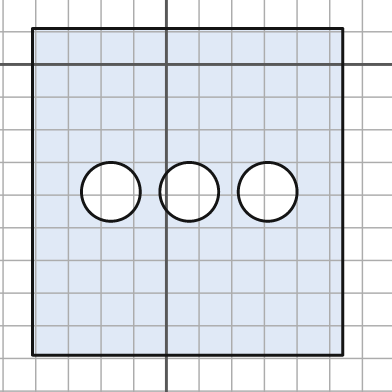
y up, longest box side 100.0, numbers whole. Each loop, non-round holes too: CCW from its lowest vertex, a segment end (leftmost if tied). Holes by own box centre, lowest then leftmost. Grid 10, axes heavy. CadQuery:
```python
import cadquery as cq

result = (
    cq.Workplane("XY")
    .moveTo(-41.0, -89.0)
    .lineTo(54.0, -89.0)
    .lineTo(54.0, 11.0)
    .lineTo(-41.0, 11.0)
    .close()
    .moveTo(-17.0, -39.0)
    .circle(9.0)
    .moveTo(7.0, -39.0)
    .circle(9.0)
    .moveTo(31.0, -39.0)
    .circle(9.0)
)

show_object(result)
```